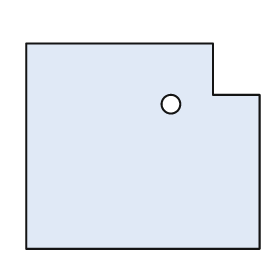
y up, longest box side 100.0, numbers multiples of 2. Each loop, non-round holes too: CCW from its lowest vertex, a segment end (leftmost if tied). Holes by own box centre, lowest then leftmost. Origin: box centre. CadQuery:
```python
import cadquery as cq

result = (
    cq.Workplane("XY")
    .moveTo(-50.0, -44.0)
    .lineTo(50.0, -44.0)
    .lineTo(50.0, 22.0)
    .lineTo(30.0, 22.0)
    .lineTo(30.0, 44.0)
    .lineTo(-50.0, 44.0)
    .close()
    .moveTo(12.0, 18.0)
    .circle(4.0)
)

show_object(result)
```